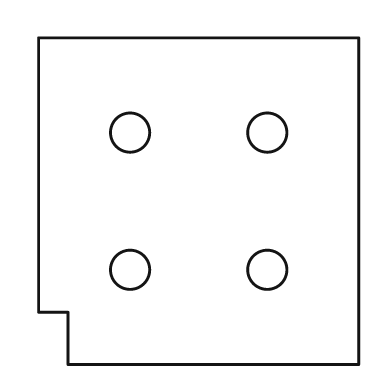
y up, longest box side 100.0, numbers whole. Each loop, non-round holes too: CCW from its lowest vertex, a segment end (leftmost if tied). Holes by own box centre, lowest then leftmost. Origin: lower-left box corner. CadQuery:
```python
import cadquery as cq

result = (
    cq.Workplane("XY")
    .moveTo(9.0, 0.0)
    .lineTo(98.0, 0.0)
    .lineTo(98.0, 100.0)
    .lineTo(0.0, 100.0)
    .lineTo(0.0, 16.0)
    .lineTo(9.0, 16.0)
    .close()
    .moveTo(28.0, 29.0)
    .circle(6.0)
    .moveTo(70.0, 29.0)
    .circle(6.0)
    .moveTo(28.0, 71.0)
    .circle(6.0)
    .moveTo(70.0, 71.0)
    .circle(6.0)
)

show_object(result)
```